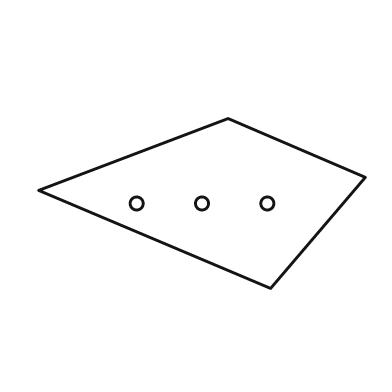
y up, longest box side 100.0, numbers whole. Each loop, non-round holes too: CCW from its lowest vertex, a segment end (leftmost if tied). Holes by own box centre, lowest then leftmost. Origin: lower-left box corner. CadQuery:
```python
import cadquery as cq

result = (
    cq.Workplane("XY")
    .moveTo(71.0, 0.0)
    .lineTo(100.0, 34.0)
    .lineTo(58.0, 52.0)
    .lineTo(0.0, 30.0)
    .close()
    .moveTo(30.0, 26.0)
    .circle(2.0)
    .moveTo(50.0, 26.0)
    .circle(2.0)
    .moveTo(70.0, 26.0)
    .circle(2.0)
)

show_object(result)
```